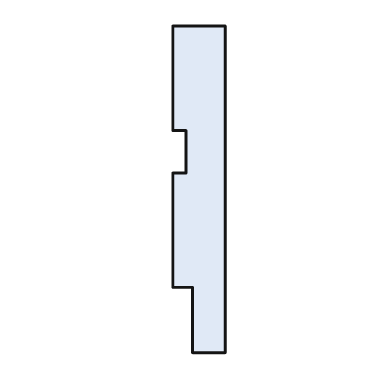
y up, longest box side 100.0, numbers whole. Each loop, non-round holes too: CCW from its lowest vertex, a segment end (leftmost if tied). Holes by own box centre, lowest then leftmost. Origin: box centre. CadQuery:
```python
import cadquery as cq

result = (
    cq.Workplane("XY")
    .moveTo(-2.0, -50.0)
    .lineTo(8.0, -50.0)
    .lineTo(8.0, 50.0)
    .lineTo(-8.0, 50.0)
    .lineTo(-8.0, 18.0)
    .lineTo(-4.0, 18.0)
    .lineTo(-4.0, 5.0)
    .lineTo(-8.0, 5.0)
    .lineTo(-8.0, -30.0)
    .lineTo(-2.0, -30.0)
    .close()
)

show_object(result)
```